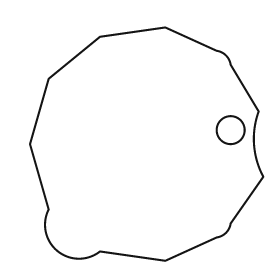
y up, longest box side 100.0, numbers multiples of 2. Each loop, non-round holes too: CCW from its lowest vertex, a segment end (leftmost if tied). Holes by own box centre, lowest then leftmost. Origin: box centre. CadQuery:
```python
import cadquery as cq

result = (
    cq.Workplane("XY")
    .moveTo(8.0, -50.0)
    .lineTo(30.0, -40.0)
    .threePointArc((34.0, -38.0), (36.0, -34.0))
    .lineTo(50.0, -14.0)
    .threePointArc((46.0, 0.0), (48.0, 14.0))
    .lineTo(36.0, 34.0)
    .threePointArc((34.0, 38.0), (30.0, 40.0))
    .lineTo(8.0, 50.0)
    .lineTo(-20.0, 46.0)
    .lineTo(-42.0, 28.0)
    .lineTo(-50.0, 0.0)
    .lineTo(-42.0, -28.0)
    .threePointArc((-38.0, -46.0), (-20.0, -46.0))
    .close()
    .moveTo(36.0, 6.0)
    .circle(6.0)
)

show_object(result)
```